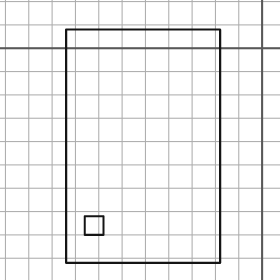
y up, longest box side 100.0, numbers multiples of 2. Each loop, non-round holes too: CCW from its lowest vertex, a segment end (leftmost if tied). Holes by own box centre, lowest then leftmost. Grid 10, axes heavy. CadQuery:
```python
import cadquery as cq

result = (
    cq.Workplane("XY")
    .moveTo(-84.0, -92.0)
    .lineTo(-18.0, -92.0)
    .lineTo(-18.0, 8.0)
    .lineTo(-84.0, 8.0)
    .close()
    .moveTo(-76.0, -80.0)
    .lineTo(-68.0, -80.0)
    .lineTo(-68.0, -72.0)
    .lineTo(-76.0, -72.0)
    .close()
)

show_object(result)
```